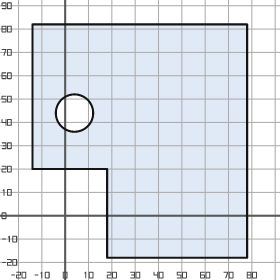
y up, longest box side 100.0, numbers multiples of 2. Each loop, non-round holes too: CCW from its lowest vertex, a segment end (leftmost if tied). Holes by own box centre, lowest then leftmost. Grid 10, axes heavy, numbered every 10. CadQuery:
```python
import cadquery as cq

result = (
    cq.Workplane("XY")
    .moveTo(18.0, -18.0)
    .lineTo(78.0, -18.0)
    .lineTo(78.0, 82.0)
    .lineTo(-14.0, 82.0)
    .lineTo(-14.0, 20.0)
    .lineTo(18.0, 20.0)
    .close()
    .moveTo(4.0, 44.0)
    .circle(8.0)
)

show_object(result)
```